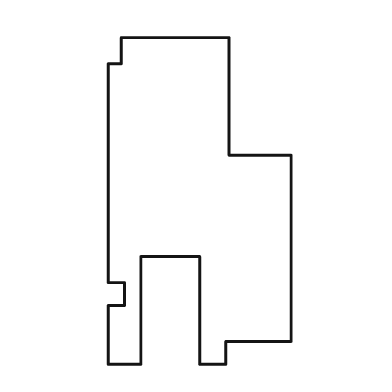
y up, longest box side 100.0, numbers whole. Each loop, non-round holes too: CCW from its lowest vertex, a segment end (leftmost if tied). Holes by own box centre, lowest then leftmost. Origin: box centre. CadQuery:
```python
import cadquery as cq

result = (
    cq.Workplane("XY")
    .moveTo(-28.0, -50.0)
    .lineTo(-18.0, -50.0)
    .lineTo(-18.0, -17.0)
    .lineTo(0.0, -17.0)
    .lineTo(0.0, -50.0)
    .lineTo(8.0, -50.0)
    .lineTo(8.0, -43.0)
    .lineTo(28.0, -43.0)
    .lineTo(28.0, 14.0)
    .lineTo(9.0, 14.0)
    .lineTo(9.0, 50.0)
    .lineTo(-24.0, 50.0)
    .lineTo(-24.0, 42.0)
    .lineTo(-28.0, 42.0)
    .lineTo(-28.0, -25.0)
    .lineTo(-23.0, -25.0)
    .lineTo(-23.0, -32.0)
    .lineTo(-28.0, -32.0)
    .close()
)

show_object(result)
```